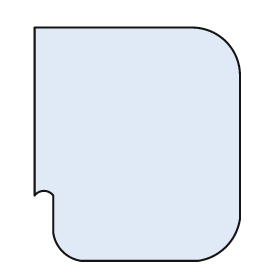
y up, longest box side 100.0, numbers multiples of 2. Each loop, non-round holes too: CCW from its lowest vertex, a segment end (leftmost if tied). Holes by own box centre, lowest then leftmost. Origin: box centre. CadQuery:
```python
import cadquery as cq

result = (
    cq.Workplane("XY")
    .moveTo(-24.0, -50.0)
    .lineTo(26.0, -50.0)
    .threePointArc((38.0, -44.0), (44.0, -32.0))
    .lineTo(44.0, 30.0)
    .threePointArc((38.0, 44.0), (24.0, 50.0))
    .lineTo(-44.0, 50.0)
    .lineTo(-44.0, -22.0)
    .threePointArc((-40.0, -20.0), (-36.0, -22.0))
    .lineTo(-36.0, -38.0)
    .threePointArc((-32.0, -46.0), (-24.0, -50.0))
    .close()
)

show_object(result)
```